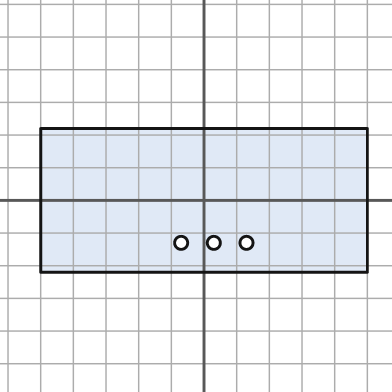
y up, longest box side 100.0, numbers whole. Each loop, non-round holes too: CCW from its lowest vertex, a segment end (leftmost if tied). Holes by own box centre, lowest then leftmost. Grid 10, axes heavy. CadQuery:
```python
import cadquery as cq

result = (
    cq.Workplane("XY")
    .moveTo(-50.0, -22.0)
    .lineTo(50.0, -22.0)
    .lineTo(50.0, 22.0)
    .lineTo(-50.0, 22.0)
    .close()
    .moveTo(-7.0, -13.0)
    .circle(2.0)
    .moveTo(3.0, -13.0)
    .circle(2.0)
    .moveTo(13.0, -13.0)
    .circle(2.0)
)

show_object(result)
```